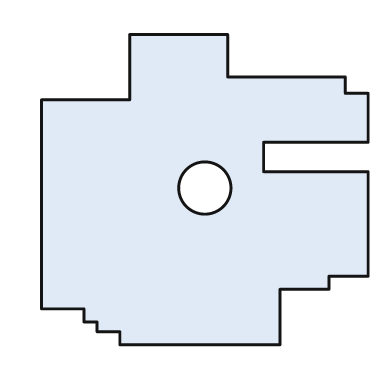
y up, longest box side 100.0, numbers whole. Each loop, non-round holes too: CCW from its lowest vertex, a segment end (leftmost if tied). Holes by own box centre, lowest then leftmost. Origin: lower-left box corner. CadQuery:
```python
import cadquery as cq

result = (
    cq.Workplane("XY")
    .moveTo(24.0, 0.0)
    .lineTo(73.0, 0.0)
    .lineTo(73.0, 17.0)
    .lineTo(88.0, 17.0)
    .lineTo(88.0, 21.0)
    .lineTo(100.0, 21.0)
    .lineTo(100.0, 53.0)
    .lineTo(68.0, 53.0)
    .lineTo(68.0, 62.0)
    .lineTo(100.0, 62.0)
    .lineTo(100.0, 77.0)
    .lineTo(93.0, 77.0)
    .lineTo(93.0, 82.0)
    .lineTo(57.0, 82.0)
    .lineTo(57.0, 95.0)
    .lineTo(27.0, 95.0)
    .lineTo(27.0, 75.0)
    .lineTo(0.0, 75.0)
    .lineTo(0.0, 11.0)
    .lineTo(13.0, 11.0)
    .lineTo(13.0, 7.0)
    .lineTo(17.0, 7.0)
    .lineTo(17.0, 4.0)
    .lineTo(24.0, 4.0)
    .close()
    .moveTo(50.0, 48.0)
    .circle(8.0)
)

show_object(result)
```